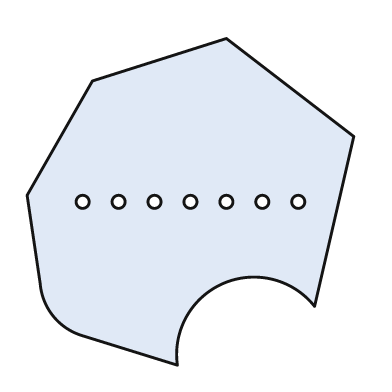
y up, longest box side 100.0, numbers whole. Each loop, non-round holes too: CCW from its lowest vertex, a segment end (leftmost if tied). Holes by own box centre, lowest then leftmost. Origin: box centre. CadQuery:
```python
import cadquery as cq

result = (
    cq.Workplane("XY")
    .moveTo(-4.0, -50.0)
    .threePointArc((10.0, -25.0), (38.0, -32.0))
    .lineTo(50.0, 20.0)
    .lineTo(11.0, 50.0)
    .lineTo(-30.0, 37.0)
    .lineTo(-50.0, 2.0)
    .lineTo(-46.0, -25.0)
    .threePointArc((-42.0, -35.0), (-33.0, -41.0))
    .close()
    .moveTo(-33.0, 0.0)
    .circle(2.0)
    .moveTo(-22.0, 0.0)
    .circle(2.0)
    .moveTo(-11.0, 0.0)
    .circle(2.0)
    .moveTo(0.0, 0.0)
    .circle(2.0)
    .moveTo(11.0, 0.0)
    .circle(2.0)
    .moveTo(22.0, 0.0)
    .circle(2.0)
    .moveTo(33.0, 0.0)
    .circle(2.0)
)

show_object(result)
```